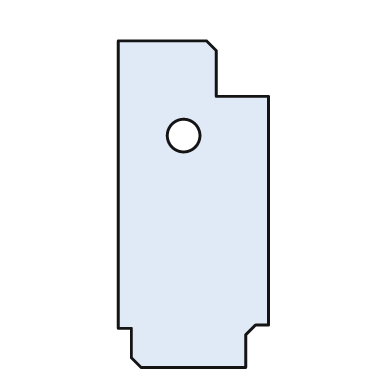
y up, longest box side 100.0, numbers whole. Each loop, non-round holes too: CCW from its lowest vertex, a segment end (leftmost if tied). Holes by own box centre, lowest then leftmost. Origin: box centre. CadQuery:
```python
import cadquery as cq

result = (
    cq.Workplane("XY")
    .moveTo(-16.0, -50.0)
    .lineTo(16.0, -50.0)
    .lineTo(16.0, -40.0)
    .lineTo(19.0, -37.0)
    .lineTo(23.0, -37.0)
    .lineTo(23.0, 33.0)
    .lineTo(7.0, 33.0)
    .lineTo(7.0, 47.0)
    .lineTo(4.0, 50.0)
    .lineTo(-23.0, 50.0)
    .lineTo(-23.0, -38.0)
    .lineTo(-19.0, -38.0)
    .lineTo(-19.0, -47.0)
    .close()
    .moveTo(-3.0, 21.0)
    .circle(5.0)
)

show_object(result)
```